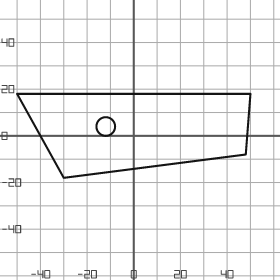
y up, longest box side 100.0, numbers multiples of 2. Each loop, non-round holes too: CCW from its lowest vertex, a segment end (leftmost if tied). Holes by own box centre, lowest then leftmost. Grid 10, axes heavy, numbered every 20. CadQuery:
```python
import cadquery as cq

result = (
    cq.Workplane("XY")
    .moveTo(-30.0, -18.0)
    .lineTo(48.0, -8.0)
    .lineTo(50.0, 18.0)
    .lineTo(-50.0, 18.0)
    .close()
    .moveTo(-12.0, 4.0)
    .circle(4.0)
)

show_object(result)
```